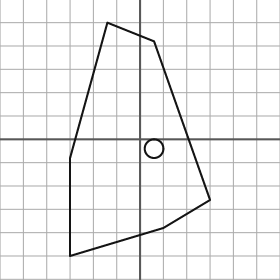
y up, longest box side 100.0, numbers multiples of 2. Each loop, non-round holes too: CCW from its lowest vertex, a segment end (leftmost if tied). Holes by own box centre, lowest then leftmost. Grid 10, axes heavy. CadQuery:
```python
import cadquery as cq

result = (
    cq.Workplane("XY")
    .moveTo(-30.0, -50.0)
    .lineTo(10.0, -38.0)
    .lineTo(30.0, -26.0)
    .lineTo(6.0, 42.0)
    .lineTo(-14.0, 50.0)
    .lineTo(-30.0, -8.0)
    .close()
    .moveTo(6.0, -4.0)
    .circle(4.0)
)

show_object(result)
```